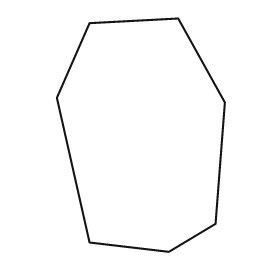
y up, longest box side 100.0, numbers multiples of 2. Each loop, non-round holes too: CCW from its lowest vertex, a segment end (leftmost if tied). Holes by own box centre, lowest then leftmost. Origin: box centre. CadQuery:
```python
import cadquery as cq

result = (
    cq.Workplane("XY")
    .moveTo(12.0, -50.0)
    .lineTo(32.0, -38.0)
    .lineTo(36.0, 14.0)
    .lineTo(16.0, 50.0)
    .lineTo(-22.0, 48.0)
    .lineTo(-36.0, 16.0)
    .lineTo(-22.0, -46.0)
    .close()
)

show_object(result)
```